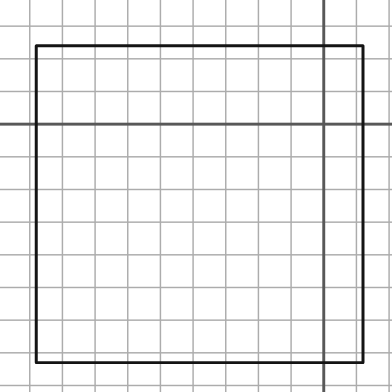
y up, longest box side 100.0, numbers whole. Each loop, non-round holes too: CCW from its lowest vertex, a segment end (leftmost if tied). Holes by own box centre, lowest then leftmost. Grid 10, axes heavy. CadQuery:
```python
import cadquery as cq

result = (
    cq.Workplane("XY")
    .moveTo(-88.0, -73.0)
    .lineTo(12.0, -73.0)
    .lineTo(12.0, 24.0)
    .lineTo(-88.0, 24.0)
    .close()
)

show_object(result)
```